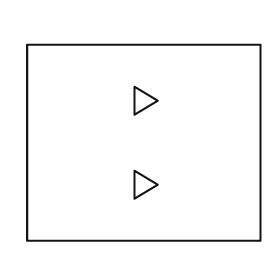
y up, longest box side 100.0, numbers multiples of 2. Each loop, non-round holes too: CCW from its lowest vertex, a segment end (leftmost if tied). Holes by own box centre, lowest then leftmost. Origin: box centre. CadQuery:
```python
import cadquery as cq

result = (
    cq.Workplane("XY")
    .moveTo(-50.0, -42.0)
    .lineTo(50.0, -42.0)
    .lineTo(50.0, 42.0)
    .lineTo(-50.0, 42.0)
    .close()
    .moveTo(-4.0, -24.0)
    .lineTo(6.0, -18.0)
    .lineTo(-4.0, -12.0)
    .close()
    .moveTo(-4.0, 12.0)
    .lineTo(6.0, 18.0)
    .lineTo(-4.0, 24.0)
    .close()
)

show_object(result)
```